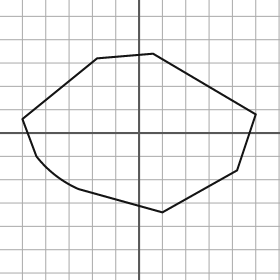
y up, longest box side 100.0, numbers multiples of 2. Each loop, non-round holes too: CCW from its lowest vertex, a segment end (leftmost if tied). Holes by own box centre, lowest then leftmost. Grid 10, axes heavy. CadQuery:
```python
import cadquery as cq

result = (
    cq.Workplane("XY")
    .moveTo(10.0, -34.0)
    .lineTo(42.0, -16.0)
    .lineTo(50.0, 8.0)
    .lineTo(6.0, 34.0)
    .lineTo(-18.0, 32.0)
    .lineTo(-50.0, 6.0)
    .lineTo(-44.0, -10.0)
    .threePointArc((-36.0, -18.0), (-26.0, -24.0))
    .close()
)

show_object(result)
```